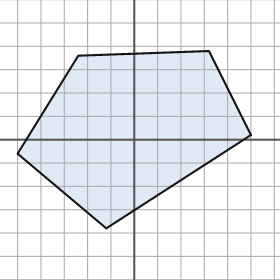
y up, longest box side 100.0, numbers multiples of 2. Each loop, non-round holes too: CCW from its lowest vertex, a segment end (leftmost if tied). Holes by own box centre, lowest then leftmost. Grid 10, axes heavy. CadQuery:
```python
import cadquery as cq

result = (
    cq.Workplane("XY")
    .moveTo(-12.0, -38.0)
    .lineTo(50.0, 2.0)
    .lineTo(32.0, 38.0)
    .lineTo(-24.0, 36.0)
    .lineTo(-50.0, -6.0)
    .close()
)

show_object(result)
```